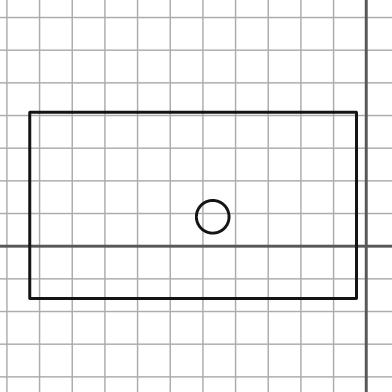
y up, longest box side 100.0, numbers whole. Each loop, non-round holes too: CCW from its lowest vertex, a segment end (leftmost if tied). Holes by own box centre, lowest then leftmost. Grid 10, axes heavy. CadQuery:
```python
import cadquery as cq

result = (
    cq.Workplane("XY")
    .moveTo(-103.0, -16.0)
    .lineTo(-3.0, -16.0)
    .lineTo(-3.0, 41.0)
    .lineTo(-103.0, 41.0)
    .close()
    .moveTo(-47.0, 9.0)
    .circle(5.0)
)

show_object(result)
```